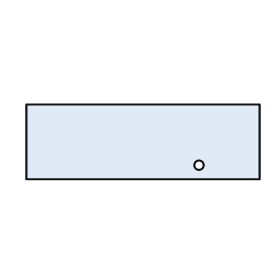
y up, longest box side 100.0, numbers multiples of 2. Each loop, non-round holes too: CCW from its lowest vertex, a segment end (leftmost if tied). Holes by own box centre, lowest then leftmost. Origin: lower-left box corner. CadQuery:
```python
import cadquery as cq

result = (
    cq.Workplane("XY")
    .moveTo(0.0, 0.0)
    .lineTo(100.0, 0.0)
    .lineTo(100.0, 32.0)
    .lineTo(0.0, 32.0)
    .close()
    .moveTo(74.0, 6.0)
    .circle(2.0)
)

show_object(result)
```